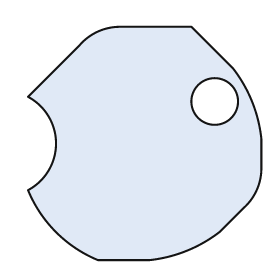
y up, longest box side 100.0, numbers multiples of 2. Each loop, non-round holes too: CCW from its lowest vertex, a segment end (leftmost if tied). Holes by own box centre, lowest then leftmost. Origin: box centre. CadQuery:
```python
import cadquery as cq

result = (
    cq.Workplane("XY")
    .moveTo(-20.0, -50.0)
    .lineTo(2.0, -50.0)
    .threePointArc((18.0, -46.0), (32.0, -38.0))
    .lineTo(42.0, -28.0)
    .threePointArc((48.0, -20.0), (50.0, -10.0))
    .lineTo(50.0, 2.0)
    .threePointArc((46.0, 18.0), (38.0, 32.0))
    .lineTo(20.0, 50.0)
    .lineTo(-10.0, 50.0)
    .threePointArc((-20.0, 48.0), (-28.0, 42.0))
    .lineTo(-50.0, 20.0)
    .threePointArc((-38.0, 0.0), (-50.0, -20.0))
    .threePointArc((-38.0, -38.0), (-20.0, -50.0))
    .close()
    .moveTo(30.0, 18.0)
    .circle(10.0)
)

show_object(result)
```